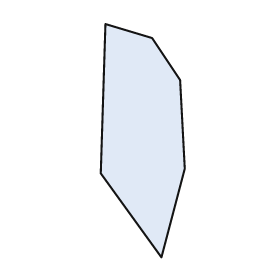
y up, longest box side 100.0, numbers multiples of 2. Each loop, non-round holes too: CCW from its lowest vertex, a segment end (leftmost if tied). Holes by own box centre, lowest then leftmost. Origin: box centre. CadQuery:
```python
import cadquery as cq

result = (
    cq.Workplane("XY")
    .moveTo(8.0, -50.0)
    .lineTo(18.0, -12.0)
    .lineTo(16.0, 26.0)
    .lineTo(4.0, 44.0)
    .lineTo(-16.0, 50.0)
    .lineTo(-18.0, -14.0)
    .close()
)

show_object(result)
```